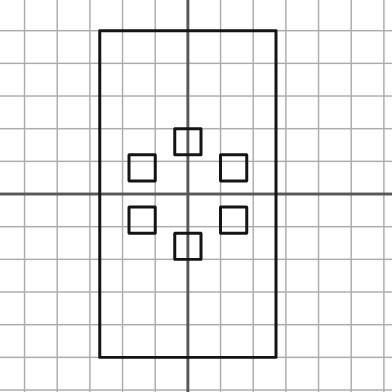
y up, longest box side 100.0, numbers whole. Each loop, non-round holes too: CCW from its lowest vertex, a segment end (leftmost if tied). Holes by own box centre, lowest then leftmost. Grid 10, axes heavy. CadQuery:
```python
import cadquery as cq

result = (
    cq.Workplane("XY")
    .moveTo(-27.0, -50.0)
    .lineTo(27.0, -50.0)
    .lineTo(27.0, 50.0)
    .lineTo(-27.0, 50.0)
    .close()
    .moveTo(-4.0, -20.0)
    .lineTo(4.0, -20.0)
    .lineTo(4.0, -12.0)
    .lineTo(-4.0, -12.0)
    .close()
    .moveTo(-18.0, -12.0)
    .lineTo(-10.0, -12.0)
    .lineTo(-10.0, -4.0)
    .lineTo(-18.0, -4.0)
    .close()
    .moveTo(10.0, -12.0)
    .lineTo(18.0, -12.0)
    .lineTo(18.0, -4.0)
    .lineTo(10.0, -4.0)
    .close()
    .moveTo(-18.0, 4.0)
    .lineTo(-10.0, 4.0)
    .lineTo(-10.0, 12.0)
    .lineTo(-18.0, 12.0)
    .close()
    .moveTo(10.0, 4.0)
    .lineTo(18.0, 4.0)
    .lineTo(18.0, 12.0)
    .lineTo(10.0, 12.0)
    .close()
    .moveTo(-4.0, 12.0)
    .lineTo(4.0, 12.0)
    .lineTo(4.0, 20.0)
    .lineTo(-4.0, 20.0)
    .close()
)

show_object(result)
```